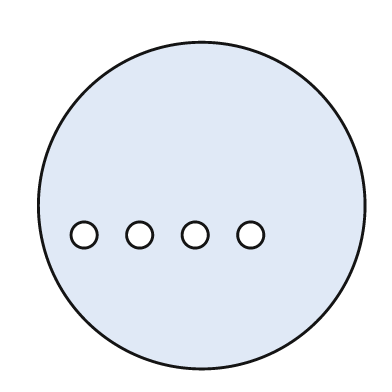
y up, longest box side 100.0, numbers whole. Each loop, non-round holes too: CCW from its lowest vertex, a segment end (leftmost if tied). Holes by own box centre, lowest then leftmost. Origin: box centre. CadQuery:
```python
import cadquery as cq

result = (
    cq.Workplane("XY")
    .moveTo(0.0, 0.0)
    .circle(50.0)
    .moveTo(-36.0, -9.0)
    .circle(4.0)
    .moveTo(-19.0, -9.0)
    .circle(4.0)
    .moveTo(-2.0, -9.0)
    .circle(4.0)
    .moveTo(15.0, -9.0)
    .circle(4.0)
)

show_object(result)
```